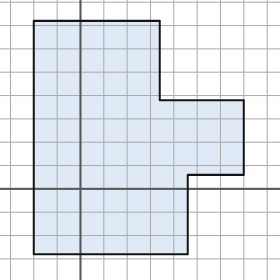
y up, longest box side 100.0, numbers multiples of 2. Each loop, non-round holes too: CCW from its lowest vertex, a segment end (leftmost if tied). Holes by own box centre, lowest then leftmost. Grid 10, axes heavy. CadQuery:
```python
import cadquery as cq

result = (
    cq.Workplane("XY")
    .moveTo(-20.0, -28.0)
    .lineTo(46.0, -28.0)
    .lineTo(46.0, 6.0)
    .lineTo(70.0, 6.0)
    .lineTo(70.0, 38.0)
    .lineTo(34.0, 38.0)
    .lineTo(34.0, 72.0)
    .lineTo(-20.0, 72.0)
    .close()
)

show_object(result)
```